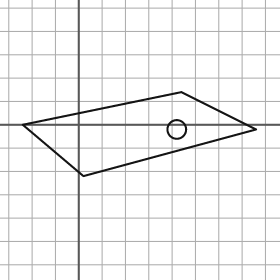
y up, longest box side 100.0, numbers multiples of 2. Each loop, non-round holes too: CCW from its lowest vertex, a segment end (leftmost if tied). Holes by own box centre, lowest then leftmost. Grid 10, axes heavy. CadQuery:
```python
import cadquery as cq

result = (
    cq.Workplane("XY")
    .moveTo(2.0, -22.0)
    .lineTo(76.0, -2.0)
    .lineTo(44.0, 14.0)
    .lineTo(-24.0, 0.0)
    .close()
    .moveTo(42.0, -2.0)
    .circle(4.0)
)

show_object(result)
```